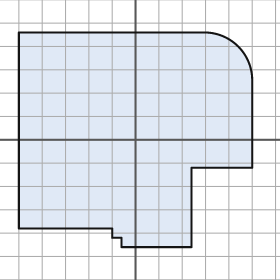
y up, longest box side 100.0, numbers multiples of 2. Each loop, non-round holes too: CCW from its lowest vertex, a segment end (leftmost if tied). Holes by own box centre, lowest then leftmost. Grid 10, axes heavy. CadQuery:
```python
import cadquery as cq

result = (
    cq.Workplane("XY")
    .moveTo(-6.0, -46.0)
    .lineTo(24.0, -46.0)
    .lineTo(24.0, -12.0)
    .lineTo(50.0, -12.0)
    .lineTo(50.0, 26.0)
    .threePointArc((44.0, 40.0), (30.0, 46.0))
    .lineTo(-50.0, 46.0)
    .lineTo(-50.0, -38.0)
    .lineTo(-10.0, -38.0)
    .lineTo(-10.0, -42.0)
    .lineTo(-6.0, -42.0)
    .close()
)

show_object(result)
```